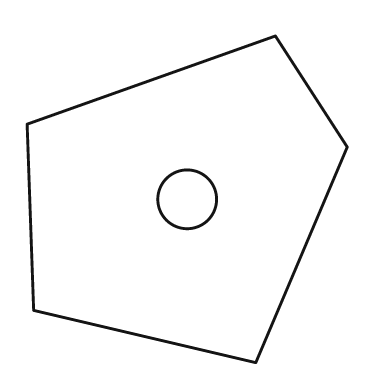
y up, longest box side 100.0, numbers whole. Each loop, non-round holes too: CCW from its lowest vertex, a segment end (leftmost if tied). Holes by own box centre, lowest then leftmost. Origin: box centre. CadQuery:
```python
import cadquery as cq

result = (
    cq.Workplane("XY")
    .moveTo(21.0, -50.0)
    .lineTo(49.0, 16.0)
    .lineTo(27.0, 50.0)
    .lineTo(-49.0, 23.0)
    .lineTo(-47.0, -34.0)
    .close()
    .moveTo(0.0, 0.0)
    .circle(9.0)
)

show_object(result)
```